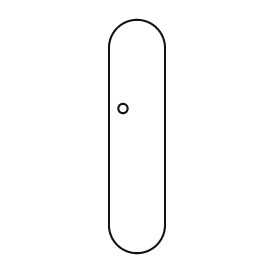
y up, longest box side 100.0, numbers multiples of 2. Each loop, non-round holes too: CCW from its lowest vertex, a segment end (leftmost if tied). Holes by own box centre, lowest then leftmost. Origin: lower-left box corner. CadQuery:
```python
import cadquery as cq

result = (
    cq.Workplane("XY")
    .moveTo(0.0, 12.0)
    .threePointArc((12.0, 0.0), (24.0, 12.0))
    .lineTo(24.0, 88.0)
    .threePointArc((12.0, 100.0), (0.0, 88.0))
    .close()
    .moveTo(6.0, 62.0)
    .circle(2.0)
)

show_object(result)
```